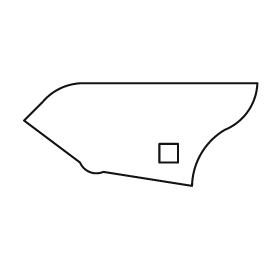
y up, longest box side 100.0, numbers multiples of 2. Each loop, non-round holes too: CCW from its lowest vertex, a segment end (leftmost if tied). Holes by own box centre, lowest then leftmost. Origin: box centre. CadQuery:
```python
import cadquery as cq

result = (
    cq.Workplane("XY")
    .moveTo(22.0, -22.0)
    .threePointArc((26.0, -8.0), (36.0, 2.0))
    .threePointArc((46.0, 10.0), (50.0, 22.0))
    .lineTo(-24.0, 22.0)
    .threePointArc((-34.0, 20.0), (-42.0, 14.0))
    .lineTo(-50.0, 6.0)
    .lineTo(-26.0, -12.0)
    .threePointArc((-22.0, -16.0), (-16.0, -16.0))
    .close()
    .moveTo(8.0, -12.0)
    .lineTo(16.0, -12.0)
    .lineTo(16.0, -4.0)
    .lineTo(8.0, -4.0)
    .close()
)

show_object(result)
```